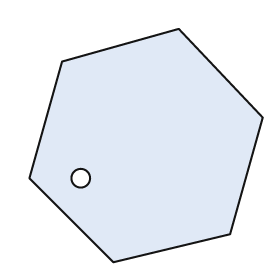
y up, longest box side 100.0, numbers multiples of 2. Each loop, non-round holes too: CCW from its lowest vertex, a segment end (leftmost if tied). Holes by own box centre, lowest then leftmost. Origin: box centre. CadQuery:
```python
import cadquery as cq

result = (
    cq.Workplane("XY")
    .moveTo(-14.0, -50.0)
    .lineTo(36.0, -38.0)
    .lineTo(50.0, 12.0)
    .lineTo(14.0, 50.0)
    .lineTo(-36.0, 36.0)
    .lineTo(-50.0, -14.0)
    .close()
    .moveTo(-28.0, -14.0)
    .circle(4.0)
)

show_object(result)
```